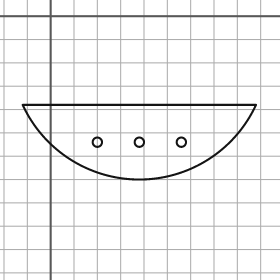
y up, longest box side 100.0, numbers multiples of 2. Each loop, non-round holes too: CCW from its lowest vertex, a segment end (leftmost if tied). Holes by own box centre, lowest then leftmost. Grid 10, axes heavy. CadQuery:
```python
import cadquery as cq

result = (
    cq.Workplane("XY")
    .moveTo(-12.0, -38.0)
    .threePointArc((38.0, -70.0), (88.0, -38.0))
    .close()
    .moveTo(20.0, -54.0)
    .circle(2.0)
    .moveTo(38.0, -54.0)
    .circle(2.0)
    .moveTo(56.0, -54.0)
    .circle(2.0)
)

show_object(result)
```